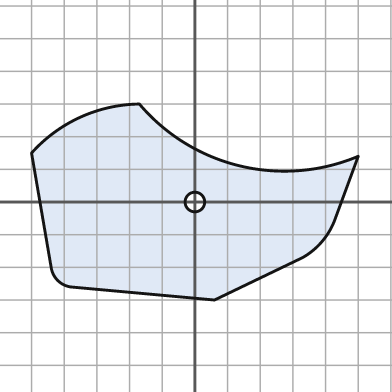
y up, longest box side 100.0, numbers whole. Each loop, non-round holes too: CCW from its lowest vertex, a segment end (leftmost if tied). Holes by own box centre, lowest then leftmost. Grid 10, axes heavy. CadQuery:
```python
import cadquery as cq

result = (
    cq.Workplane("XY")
    .moveTo(6.0, -30.0)
    .lineTo(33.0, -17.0)
    .threePointArc((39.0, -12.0), (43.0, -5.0))
    .lineTo(50.0, 14.0)
    .threePointArc((14.0, 11.0), (-17.0, 30.0))
    .threePointArc((-35.0, 26.0), (-50.0, 15.0))
    .lineTo(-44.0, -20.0)
    .threePointArc((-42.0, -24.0), (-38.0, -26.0))
    .close()
    .moveTo(0.0, 0.0)
    .circle(3.0)
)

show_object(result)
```